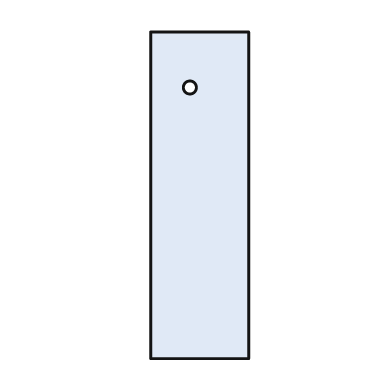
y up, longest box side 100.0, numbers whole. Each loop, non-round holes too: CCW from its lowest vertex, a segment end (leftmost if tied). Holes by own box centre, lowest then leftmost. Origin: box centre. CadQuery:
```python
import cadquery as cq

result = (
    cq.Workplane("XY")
    .moveTo(-15.0, -50.0)
    .lineTo(15.0, -50.0)
    .lineTo(15.0, 50.0)
    .lineTo(-15.0, 50.0)
    .close()
    .moveTo(-3.0, 33.0)
    .circle(2.0)
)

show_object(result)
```